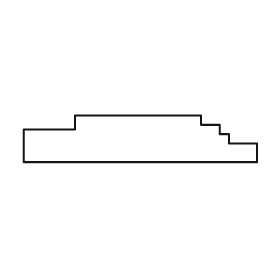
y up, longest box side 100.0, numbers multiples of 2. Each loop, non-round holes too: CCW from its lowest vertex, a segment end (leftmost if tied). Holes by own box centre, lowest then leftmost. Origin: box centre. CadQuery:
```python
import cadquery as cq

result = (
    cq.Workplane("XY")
    .moveTo(-50.0, -10.0)
    .lineTo(50.0, -10.0)
    .lineTo(50.0, -2.0)
    .lineTo(38.0, -2.0)
    .lineTo(38.0, 2.0)
    .lineTo(34.0, 2.0)
    .lineTo(34.0, 6.0)
    .lineTo(26.0, 6.0)
    .lineTo(26.0, 10.0)
    .lineTo(-28.0, 10.0)
    .lineTo(-28.0, 4.0)
    .lineTo(-50.0, 4.0)
    .close()
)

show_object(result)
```